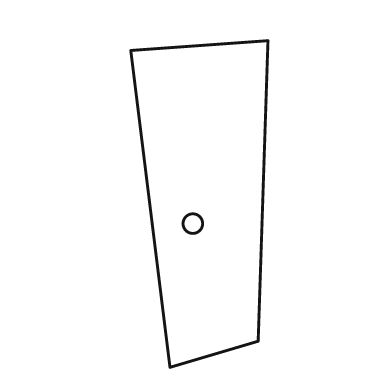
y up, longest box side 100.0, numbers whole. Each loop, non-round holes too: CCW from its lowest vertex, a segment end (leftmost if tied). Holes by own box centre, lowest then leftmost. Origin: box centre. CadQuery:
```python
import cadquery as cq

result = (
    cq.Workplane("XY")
    .moveTo(-9.0, -50.0)
    .lineTo(18.0, -42.0)
    .lineTo(21.0, 50.0)
    .lineTo(-21.0, 47.0)
    .close()
    .moveTo(-2.0, -6.0)
    .circle(3.0)
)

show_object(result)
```